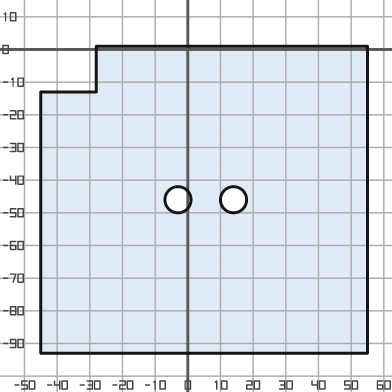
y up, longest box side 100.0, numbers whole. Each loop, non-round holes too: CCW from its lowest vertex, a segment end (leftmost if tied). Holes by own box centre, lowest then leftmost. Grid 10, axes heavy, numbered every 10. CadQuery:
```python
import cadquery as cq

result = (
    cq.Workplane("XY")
    .moveTo(-45.0, -93.0)
    .lineTo(55.0, -93.0)
    .lineTo(55.0, 1.0)
    .lineTo(-28.0, 1.0)
    .lineTo(-28.0, -13.0)
    .lineTo(-45.0, -13.0)
    .close()
    .moveTo(-3.0, -46.0)
    .circle(4.0)
    .moveTo(14.0, -46.0)
    .circle(4.0)
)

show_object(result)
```